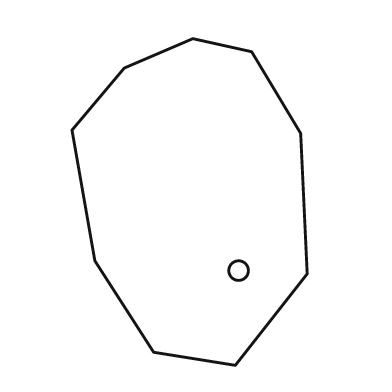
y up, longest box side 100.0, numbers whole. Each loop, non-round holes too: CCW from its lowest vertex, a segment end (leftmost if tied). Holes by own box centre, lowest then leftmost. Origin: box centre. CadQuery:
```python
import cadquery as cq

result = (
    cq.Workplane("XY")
    .moveTo(14.0, -50.0)
    .lineTo(36.0, -22.0)
    .lineTo(34.0, 21.0)
    .lineTo(19.0, 46.0)
    .lineTo(1.0, 50.0)
    .lineTo(-20.0, 41.0)
    .lineTo(-36.0, 22.0)
    .lineTo(-29.0, -18.0)
    .lineTo(-11.0, -46.0)
    .close()
    .moveTo(15.0, -21.0)
    .circle(3.0)
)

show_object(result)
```